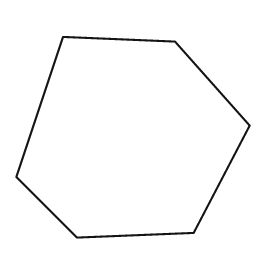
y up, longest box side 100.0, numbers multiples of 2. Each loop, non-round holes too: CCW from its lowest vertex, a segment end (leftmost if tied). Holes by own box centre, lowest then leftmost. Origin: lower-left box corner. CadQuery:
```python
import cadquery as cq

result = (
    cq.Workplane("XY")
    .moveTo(26.0, 0.0)
    .lineTo(76.0, 2.0)
    .lineTo(100.0, 48.0)
    .lineTo(68.0, 84.0)
    .lineTo(20.0, 86.0)
    .lineTo(0.0, 26.0)
    .close()
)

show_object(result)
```